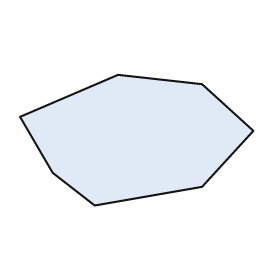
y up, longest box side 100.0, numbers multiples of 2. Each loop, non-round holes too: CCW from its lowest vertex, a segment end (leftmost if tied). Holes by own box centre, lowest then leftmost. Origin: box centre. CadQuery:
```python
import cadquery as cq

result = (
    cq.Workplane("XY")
    .moveTo(-18.0, -28.0)
    .lineTo(28.0, -20.0)
    .lineTo(50.0, 4.0)
    .lineTo(28.0, 24.0)
    .lineTo(-8.0, 28.0)
    .lineTo(-50.0, 10.0)
    .lineTo(-36.0, -14.0)
    .close()
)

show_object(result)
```